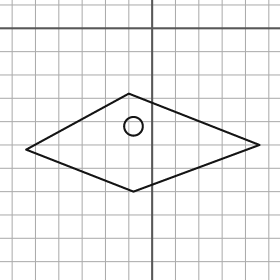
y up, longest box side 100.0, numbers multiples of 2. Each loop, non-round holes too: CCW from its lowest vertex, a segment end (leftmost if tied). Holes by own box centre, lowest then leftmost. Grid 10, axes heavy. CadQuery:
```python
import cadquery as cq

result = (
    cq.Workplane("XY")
    .moveTo(-8.0, -70.0)
    .lineTo(46.0, -50.0)
    .lineTo(-10.0, -28.0)
    .lineTo(-54.0, -52.0)
    .close()
    .moveTo(-8.0, -42.0)
    .circle(4.0)
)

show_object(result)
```